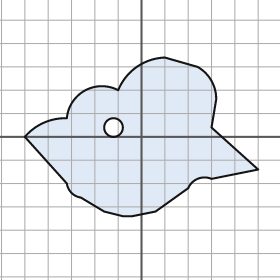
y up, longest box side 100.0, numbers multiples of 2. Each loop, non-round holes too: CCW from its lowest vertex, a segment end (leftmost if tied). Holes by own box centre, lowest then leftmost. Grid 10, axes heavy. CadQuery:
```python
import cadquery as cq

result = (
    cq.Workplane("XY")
    .moveTo(-8.0, -34.0)
    .lineTo(-4.0, -34.0)
    .lineTo(6.0, -32.0)
    .lineTo(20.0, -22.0)
    .threePointArc((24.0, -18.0), (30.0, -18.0))
    .lineTo(50.0, -14.0)
    .lineTo(30.0, 4.0)
    .lineTo(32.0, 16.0)
    .threePointArc((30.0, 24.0), (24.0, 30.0))
    .lineTo(10.0, 34.0)
    .threePointArc((-2.0, 30.0), (-10.0, 20.0))
    .threePointArc((-24.0, 20.0), (-32.0, 8.0))
    .threePointArc((-42.0, 6.0), (-50.0, 0.0))
    .lineTo(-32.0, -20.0)
    .threePointArc((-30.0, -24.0), (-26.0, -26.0))
    .lineTo(-16.0, -32.0)
    .close()
    .moveTo(-12.0, 4.0)
    .circle(4.0)
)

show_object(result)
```